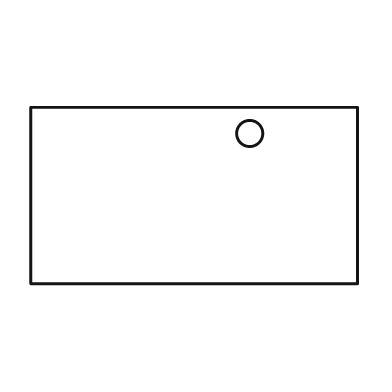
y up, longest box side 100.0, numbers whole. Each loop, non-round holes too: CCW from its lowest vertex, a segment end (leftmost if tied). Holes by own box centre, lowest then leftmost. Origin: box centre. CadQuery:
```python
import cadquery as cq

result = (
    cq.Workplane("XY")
    .moveTo(-50.0, -27.0)
    .lineTo(50.0, -27.0)
    .lineTo(50.0, 27.0)
    .lineTo(-50.0, 27.0)
    .close()
    .moveTo(17.0, 19.0)
    .circle(4.0)
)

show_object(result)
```